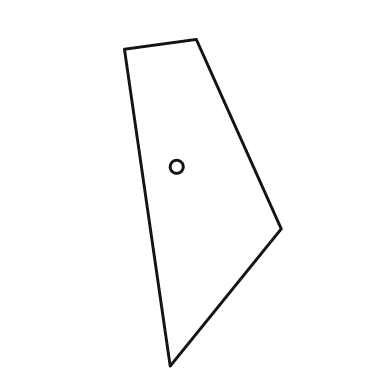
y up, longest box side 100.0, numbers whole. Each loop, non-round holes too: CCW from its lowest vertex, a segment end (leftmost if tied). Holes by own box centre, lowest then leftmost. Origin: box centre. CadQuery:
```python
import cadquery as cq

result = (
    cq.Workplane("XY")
    .moveTo(-10.0, -50.0)
    .lineTo(24.0, -8.0)
    .lineTo(-2.0, 50.0)
    .lineTo(-24.0, 47.0)
    .close()
    .moveTo(-8.0, 11.0)
    .circle(2.0)
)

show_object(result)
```